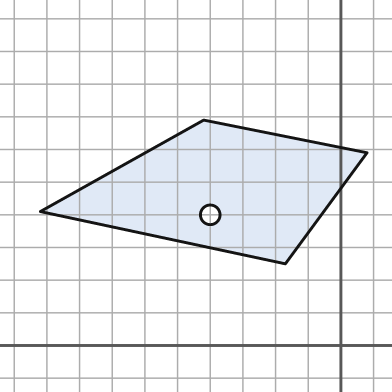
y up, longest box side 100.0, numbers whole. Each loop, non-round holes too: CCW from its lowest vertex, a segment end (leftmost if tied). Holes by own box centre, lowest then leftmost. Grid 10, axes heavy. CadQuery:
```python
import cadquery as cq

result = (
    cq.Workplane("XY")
    .moveTo(-17.0, 25.0)
    .lineTo(8.0, 59.0)
    .lineTo(-42.0, 69.0)
    .lineTo(-92.0, 41.0)
    .close()
    .moveTo(-40.0, 40.0)
    .circle(3.0)
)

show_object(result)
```